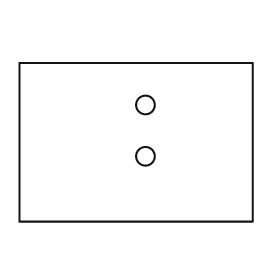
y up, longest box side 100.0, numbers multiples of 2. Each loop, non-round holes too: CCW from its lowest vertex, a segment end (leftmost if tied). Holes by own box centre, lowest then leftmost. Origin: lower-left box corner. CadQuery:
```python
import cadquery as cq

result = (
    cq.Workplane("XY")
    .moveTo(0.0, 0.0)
    .lineTo(100.0, 0.0)
    .lineTo(100.0, 68.0)
    .lineTo(0.0, 68.0)
    .close()
    .moveTo(54.0, 28.0)
    .circle(4.0)
    .moveTo(54.0, 50.0)
    .circle(4.0)
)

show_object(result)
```